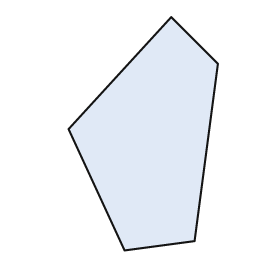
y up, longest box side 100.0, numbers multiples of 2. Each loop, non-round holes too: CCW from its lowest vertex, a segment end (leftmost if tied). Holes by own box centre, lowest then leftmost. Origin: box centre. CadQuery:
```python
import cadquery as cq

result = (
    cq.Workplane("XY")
    .moveTo(-8.0, -50.0)
    .lineTo(22.0, -46.0)
    .lineTo(32.0, 30.0)
    .lineTo(12.0, 50.0)
    .lineTo(-32.0, 2.0)
    .close()
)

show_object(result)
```